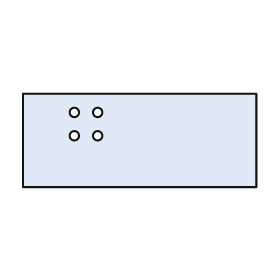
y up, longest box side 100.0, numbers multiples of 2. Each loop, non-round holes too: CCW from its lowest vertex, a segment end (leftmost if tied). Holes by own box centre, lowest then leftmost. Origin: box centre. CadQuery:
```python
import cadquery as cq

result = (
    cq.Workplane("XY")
    .moveTo(-50.0, -20.0)
    .lineTo(50.0, -20.0)
    .lineTo(50.0, 20.0)
    .lineTo(-50.0, 20.0)
    .close()
    .moveTo(-28.0, 2.0)
    .circle(2.0)
    .moveTo(-18.0, 2.0)
    .circle(2.0)
    .moveTo(-28.0, 12.0)
    .circle(2.0)
    .moveTo(-18.0, 12.0)
    .circle(2.0)
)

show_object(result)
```